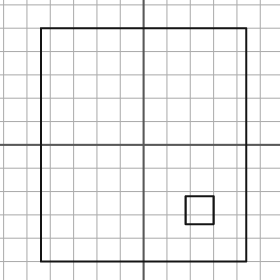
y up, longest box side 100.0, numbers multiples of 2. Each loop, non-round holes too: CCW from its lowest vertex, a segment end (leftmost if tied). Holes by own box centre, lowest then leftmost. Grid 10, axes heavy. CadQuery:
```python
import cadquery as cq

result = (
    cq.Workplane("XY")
    .moveTo(-44.0, -50.0)
    .lineTo(44.0, -50.0)
    .lineTo(44.0, 50.0)
    .lineTo(-44.0, 50.0)
    .close()
    .moveTo(18.0, -34.0)
    .lineTo(30.0, -34.0)
    .lineTo(30.0, -22.0)
    .lineTo(18.0, -22.0)
    .close()
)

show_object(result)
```